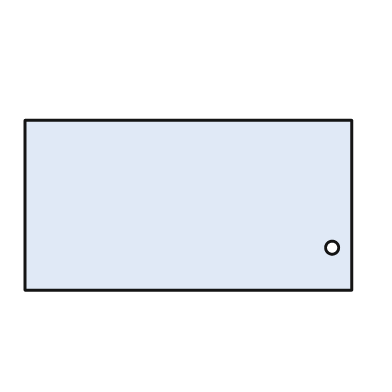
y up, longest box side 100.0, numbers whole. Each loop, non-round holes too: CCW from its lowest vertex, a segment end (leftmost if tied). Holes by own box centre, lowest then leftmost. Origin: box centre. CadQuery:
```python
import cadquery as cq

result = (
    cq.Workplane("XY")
    .moveTo(-50.0, -26.0)
    .lineTo(50.0, -26.0)
    .lineTo(50.0, 26.0)
    .lineTo(-50.0, 26.0)
    .close()
    .moveTo(44.0, -13.0)
    .circle(2.0)
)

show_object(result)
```